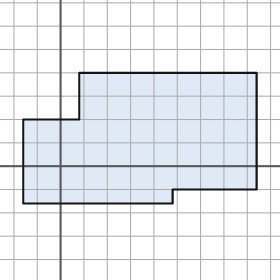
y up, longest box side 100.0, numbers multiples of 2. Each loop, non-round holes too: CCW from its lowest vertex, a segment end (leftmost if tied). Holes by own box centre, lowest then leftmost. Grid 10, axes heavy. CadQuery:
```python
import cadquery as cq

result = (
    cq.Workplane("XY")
    .moveTo(-16.0, -16.0)
    .lineTo(48.0, -16.0)
    .lineTo(48.0, -10.0)
    .lineTo(84.0, -10.0)
    .lineTo(84.0, 40.0)
    .lineTo(8.0, 40.0)
    .lineTo(8.0, 20.0)
    .lineTo(-16.0, 20.0)
    .close()
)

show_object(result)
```